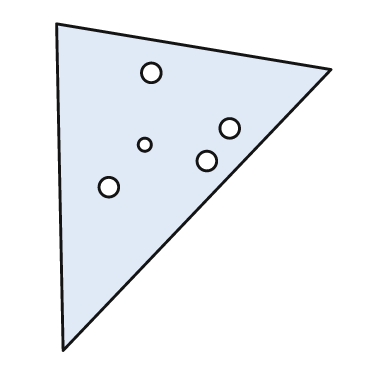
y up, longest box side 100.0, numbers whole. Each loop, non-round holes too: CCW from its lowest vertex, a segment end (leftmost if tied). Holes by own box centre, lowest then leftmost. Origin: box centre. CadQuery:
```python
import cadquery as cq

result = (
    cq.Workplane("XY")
    .moveTo(-40.0, -50.0)
    .lineTo(42.0, 36.0)
    .lineTo(-42.0, 50.0)
    .close()
    .moveTo(-26.0, 0.0)
    .circle(3.0)
    .moveTo(4.0, 8.0)
    .circle(3.0)
    .moveTo(-15.0, 13.0)
    .circle(2.0)
    .moveTo(11.0, 18.0)
    .circle(3.0)
    .moveTo(-13.0, 35.0)
    .circle(3.0)
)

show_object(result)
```